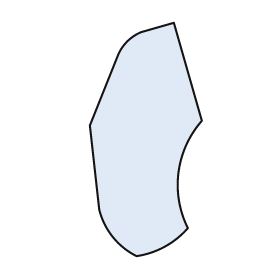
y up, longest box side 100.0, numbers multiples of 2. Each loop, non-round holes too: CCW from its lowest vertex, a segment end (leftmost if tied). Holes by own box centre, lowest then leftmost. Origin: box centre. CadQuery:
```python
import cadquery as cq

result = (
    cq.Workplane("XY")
    .moveTo(-4.0, -50.0)
    .threePointArc((8.0, -46.0), (18.0, -38.0))
    .threePointArc((14.0, -14.0), (24.0, 8.0))
    .lineTo(12.0, 50.0)
    .lineTo(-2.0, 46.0)
    .threePointArc((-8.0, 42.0), (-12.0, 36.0))
    .lineTo(-24.0, 6.0)
    .lineTo(-20.0, -30.0)
    .threePointArc((-14.0, -42.0), (-4.0, -50.0))
    .close()
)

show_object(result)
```